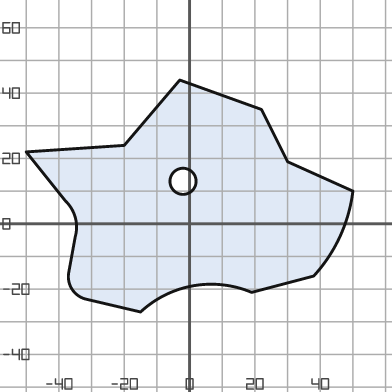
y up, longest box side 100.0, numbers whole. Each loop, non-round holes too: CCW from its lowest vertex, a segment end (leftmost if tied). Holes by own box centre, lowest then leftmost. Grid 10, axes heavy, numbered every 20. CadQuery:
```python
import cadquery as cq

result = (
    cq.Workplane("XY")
    .moveTo(-15.0, -27.0)
    .threePointArc((1.0, -19.0), (19.0, -21.0))
    .lineTo(38.0, -16.0)
    .threePointArc((46.0, -4.0), (50.0, 10.0))
    .lineTo(30.0, 19.0)
    .lineTo(22.0, 35.0)
    .lineTo(-3.0, 44.0)
    .lineTo(-20.0, 24.0)
    .lineTo(-50.0, 22.0)
    .lineTo(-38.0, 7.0)
    .threePointArc((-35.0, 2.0), (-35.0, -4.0))
    .lineTo(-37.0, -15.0)
    .threePointArc((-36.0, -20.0), (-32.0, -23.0))
    .close()
    .moveTo(-2.0, 13.0)
    .circle(4.0)
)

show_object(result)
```